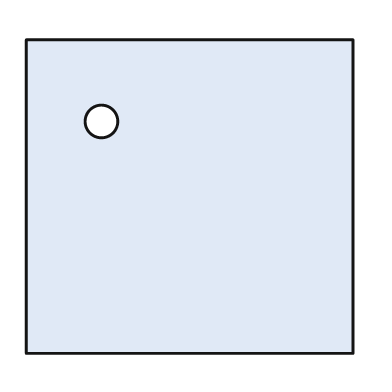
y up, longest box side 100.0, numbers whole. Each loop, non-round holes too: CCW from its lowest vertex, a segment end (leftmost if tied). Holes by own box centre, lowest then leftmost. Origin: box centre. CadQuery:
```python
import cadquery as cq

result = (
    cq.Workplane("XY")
    .moveTo(-50.0, -48.0)
    .lineTo(50.0, -48.0)
    .lineTo(50.0, 48.0)
    .lineTo(-50.0, 48.0)
    .close()
    .moveTo(-27.0, 23.0)
    .circle(5.0)
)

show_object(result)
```